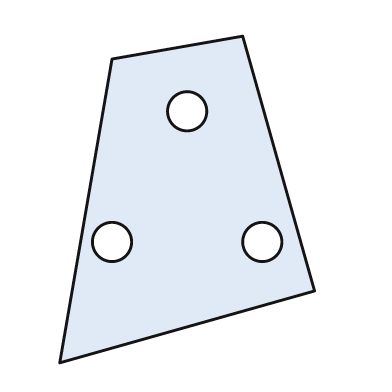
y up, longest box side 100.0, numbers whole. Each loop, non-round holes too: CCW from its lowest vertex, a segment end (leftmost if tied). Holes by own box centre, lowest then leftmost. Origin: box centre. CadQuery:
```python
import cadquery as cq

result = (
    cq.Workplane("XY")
    .moveTo(-39.0, -50.0)
    .lineTo(39.0, -28.0)
    .lineTo(17.0, 50.0)
    .lineTo(-23.0, 43.0)
    .close()
    .moveTo(-23.0, -13.0)
    .circle(6.0)
    .moveTo(23.0, -13.0)
    .circle(6.0)
    .moveTo(0.0, 27.0)
    .circle(6.0)
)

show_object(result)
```